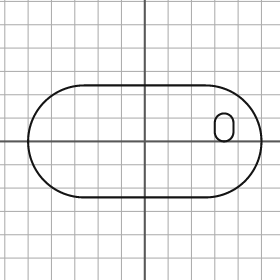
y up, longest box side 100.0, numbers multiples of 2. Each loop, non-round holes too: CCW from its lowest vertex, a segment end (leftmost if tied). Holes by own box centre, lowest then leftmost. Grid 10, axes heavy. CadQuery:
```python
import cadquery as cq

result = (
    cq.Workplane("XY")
    .moveTo(-26.0, -24.0)
    .lineTo(26.0, -24.0)
    .threePointArc((50.0, 0.0), (26.0, 24.0))
    .lineTo(-26.0, 24.0)
    .threePointArc((-50.0, 0.0), (-26.0, -24.0))
    .close()
    .moveTo(30.0, 4.0)
    .threePointArc((34.0, 0.0), (38.0, 4.0))
    .lineTo(38.0, 8.0)
    .threePointArc((34.0, 12.0), (30.0, 8.0))
    .close()
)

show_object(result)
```